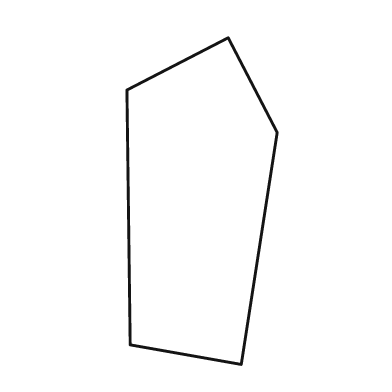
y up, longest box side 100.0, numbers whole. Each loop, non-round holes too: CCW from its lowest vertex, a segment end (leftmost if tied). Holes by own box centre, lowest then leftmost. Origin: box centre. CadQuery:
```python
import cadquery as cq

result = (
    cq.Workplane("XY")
    .moveTo(12.0, -50.0)
    .lineTo(23.0, 21.0)
    .lineTo(8.0, 50.0)
    .lineTo(-23.0, 34.0)
    .lineTo(-22.0, -44.0)
    .close()
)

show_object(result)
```